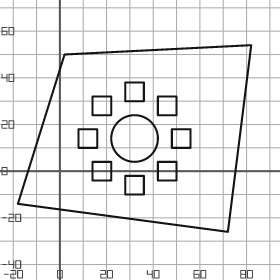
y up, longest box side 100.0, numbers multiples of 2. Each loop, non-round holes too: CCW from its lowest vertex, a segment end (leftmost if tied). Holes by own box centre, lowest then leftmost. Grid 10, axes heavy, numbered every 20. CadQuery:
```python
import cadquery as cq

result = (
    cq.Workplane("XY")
    .moveTo(72.0, -26.0)
    .lineTo(82.0, 54.0)
    .lineTo(2.0, 50.0)
    .lineTo(-18.0, -14.0)
    .close()
    .moveTo(28.0, -10.0)
    .lineTo(36.0, -10.0)
    .lineTo(36.0, -2.0)
    .lineTo(28.0, -2.0)
    .close()
    .moveTo(14.0, -4.0)
    .lineTo(22.0, -4.0)
    .lineTo(22.0, 4.0)
    .lineTo(14.0, 4.0)
    .close()
    .moveTo(42.0, -4.0)
    .lineTo(50.0, -4.0)
    .lineTo(50.0, 4.0)
    .lineTo(42.0, 4.0)
    .close()
    .moveTo(8.0, 10.0)
    .lineTo(16.0, 10.0)
    .lineTo(16.0, 18.0)
    .lineTo(8.0, 18.0)
    .close()
    .moveTo(32.0, 14.0)
    .circle(10.0)
    .moveTo(48.0, 10.0)
    .lineTo(56.0, 10.0)
    .lineTo(56.0, 18.0)
    .lineTo(48.0, 18.0)
    .close()
    .moveTo(14.0, 24.0)
    .lineTo(22.0, 24.0)
    .lineTo(22.0, 32.0)
    .lineTo(14.0, 32.0)
    .close()
    .moveTo(42.0, 24.0)
    .lineTo(50.0, 24.0)
    .lineTo(50.0, 32.0)
    .lineTo(42.0, 32.0)
    .close()
    .moveTo(28.0, 30.0)
    .lineTo(36.0, 30.0)
    .lineTo(36.0, 38.0)
    .lineTo(28.0, 38.0)
    .close()
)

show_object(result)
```